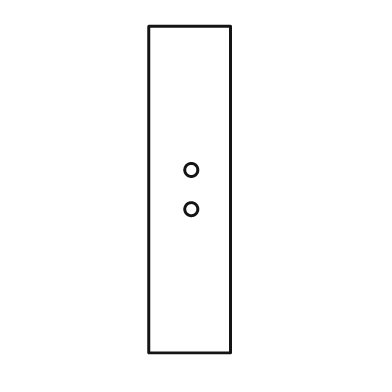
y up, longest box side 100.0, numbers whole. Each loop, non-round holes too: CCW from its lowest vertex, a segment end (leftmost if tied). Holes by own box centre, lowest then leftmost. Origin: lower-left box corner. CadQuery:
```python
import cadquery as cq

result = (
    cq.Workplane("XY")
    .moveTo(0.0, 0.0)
    .lineTo(25.0, 0.0)
    .lineTo(25.0, 100.0)
    .lineTo(0.0, 100.0)
    .close()
    .moveTo(13.0, 44.0)
    .circle(2.0)
    .moveTo(13.0, 56.0)
    .circle(2.0)
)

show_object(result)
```